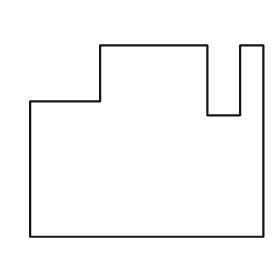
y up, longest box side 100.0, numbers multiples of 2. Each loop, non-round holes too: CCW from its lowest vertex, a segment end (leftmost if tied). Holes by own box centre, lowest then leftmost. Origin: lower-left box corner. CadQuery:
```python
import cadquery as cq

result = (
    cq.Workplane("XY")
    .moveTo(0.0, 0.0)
    .lineTo(100.0, 0.0)
    .lineTo(100.0, 82.0)
    .lineTo(90.0, 82.0)
    .lineTo(90.0, 52.0)
    .lineTo(76.0, 52.0)
    .lineTo(76.0, 82.0)
    .lineTo(30.0, 82.0)
    .lineTo(30.0, 58.0)
    .lineTo(0.0, 58.0)
    .close()
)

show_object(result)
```